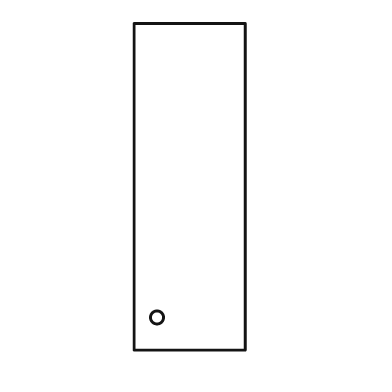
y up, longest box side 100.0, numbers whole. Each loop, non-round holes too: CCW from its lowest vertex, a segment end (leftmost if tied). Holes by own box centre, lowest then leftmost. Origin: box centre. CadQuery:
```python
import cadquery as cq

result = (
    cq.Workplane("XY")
    .moveTo(-17.0, -50.0)
    .lineTo(17.0, -50.0)
    .lineTo(17.0, 50.0)
    .lineTo(-17.0, 50.0)
    .close()
    .moveTo(-10.0, -40.0)
    .circle(2.0)
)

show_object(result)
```